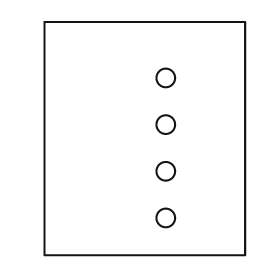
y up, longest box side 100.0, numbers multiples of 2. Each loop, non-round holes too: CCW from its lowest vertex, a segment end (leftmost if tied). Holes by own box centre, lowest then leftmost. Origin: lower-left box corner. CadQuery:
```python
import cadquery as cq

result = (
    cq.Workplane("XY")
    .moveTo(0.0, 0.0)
    .lineTo(86.0, 0.0)
    .lineTo(86.0, 100.0)
    .lineTo(0.0, 100.0)
    .close()
    .moveTo(52.0, 16.0)
    .circle(4.0)
    .moveTo(52.0, 36.0)
    .circle(4.0)
    .moveTo(52.0, 56.0)
    .circle(4.0)
    .moveTo(52.0, 76.0)
    .circle(4.0)
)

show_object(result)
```